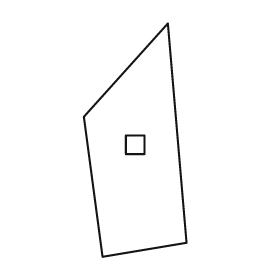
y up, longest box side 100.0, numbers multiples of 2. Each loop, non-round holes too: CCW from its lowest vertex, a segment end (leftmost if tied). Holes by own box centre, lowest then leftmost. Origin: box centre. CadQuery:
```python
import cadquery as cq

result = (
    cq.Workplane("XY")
    .moveTo(-14.0, -50.0)
    .lineTo(22.0, -44.0)
    .lineTo(14.0, 50.0)
    .lineTo(-22.0, 10.0)
    .close()
    .moveTo(-4.0, -6.0)
    .lineTo(4.0, -6.0)
    .lineTo(4.0, 2.0)
    .lineTo(-4.0, 2.0)
    .close()
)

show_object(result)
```